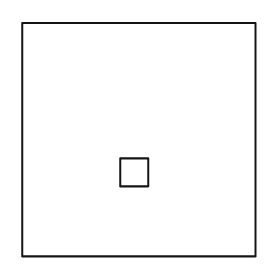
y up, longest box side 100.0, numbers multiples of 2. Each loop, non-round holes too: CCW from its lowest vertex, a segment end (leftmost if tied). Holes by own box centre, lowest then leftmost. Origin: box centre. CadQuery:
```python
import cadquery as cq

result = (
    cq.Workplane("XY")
    .moveTo(-50.0, -50.0)
    .lineTo(50.0, -50.0)
    .lineTo(50.0, 50.0)
    .lineTo(-50.0, 50.0)
    .close()
    .moveTo(-8.0, -20.0)
    .lineTo(4.0, -20.0)
    .lineTo(4.0, -8.0)
    .lineTo(-8.0, -8.0)
    .close()
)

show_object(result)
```